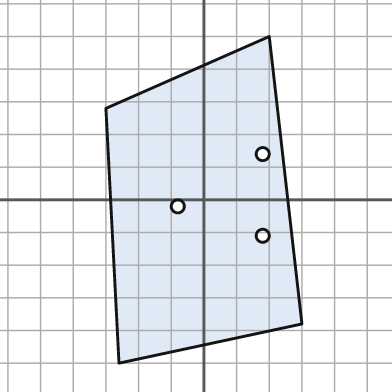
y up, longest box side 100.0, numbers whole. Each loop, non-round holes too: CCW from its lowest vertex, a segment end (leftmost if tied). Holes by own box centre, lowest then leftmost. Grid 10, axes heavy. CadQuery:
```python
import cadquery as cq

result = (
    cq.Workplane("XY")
    .moveTo(-26.0, -50.0)
    .lineTo(30.0, -38.0)
    .lineTo(20.0, 50.0)
    .lineTo(-30.0, 28.0)
    .close()
    .moveTo(18.0, -11.0)
    .circle(2.0)
    .moveTo(-8.0, -2.0)
    .circle(2.0)
    .moveTo(18.0, 14.0)
    .circle(2.0)
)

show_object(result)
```